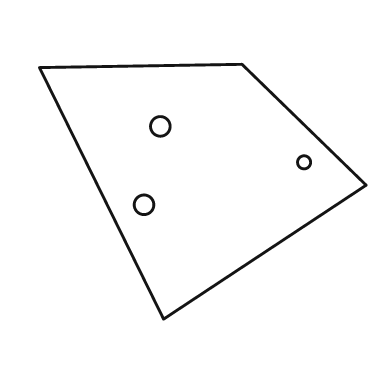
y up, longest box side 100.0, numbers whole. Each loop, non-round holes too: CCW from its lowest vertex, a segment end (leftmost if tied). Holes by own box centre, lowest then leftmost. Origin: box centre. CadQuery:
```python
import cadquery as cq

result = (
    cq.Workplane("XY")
    .moveTo(-12.0, -39.0)
    .lineTo(50.0, 2.0)
    .lineTo(12.0, 39.0)
    .lineTo(-50.0, 38.0)
    .close()
    .moveTo(-18.0, -4.0)
    .circle(3.0)
    .moveTo(31.0, 9.0)
    .circle(2.0)
    .moveTo(-13.0, 20.0)
    .circle(3.0)
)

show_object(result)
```